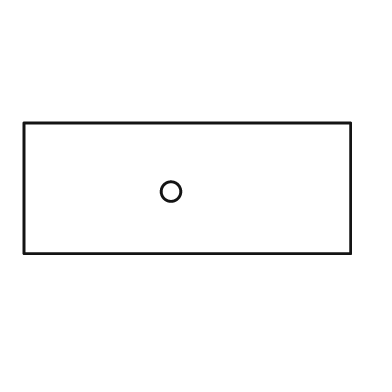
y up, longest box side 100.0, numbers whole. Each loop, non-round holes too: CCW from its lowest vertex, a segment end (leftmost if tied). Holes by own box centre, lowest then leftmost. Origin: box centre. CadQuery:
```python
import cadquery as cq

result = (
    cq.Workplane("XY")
    .moveTo(-50.0, -20.0)
    .lineTo(50.0, -20.0)
    .lineTo(50.0, 20.0)
    .lineTo(-50.0, 20.0)
    .close()
    .moveTo(-5.0, -1.0)
    .circle(3.0)
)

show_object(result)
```